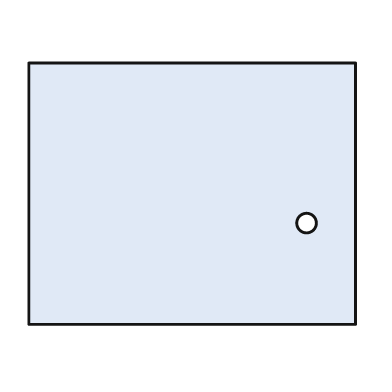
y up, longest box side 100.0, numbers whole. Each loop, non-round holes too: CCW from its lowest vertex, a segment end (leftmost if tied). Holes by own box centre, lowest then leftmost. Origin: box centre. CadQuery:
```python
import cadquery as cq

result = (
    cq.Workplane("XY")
    .moveTo(-50.0, -40.0)
    .lineTo(50.0, -40.0)
    .lineTo(50.0, 40.0)
    .lineTo(-50.0, 40.0)
    .close()
    .moveTo(35.0, -9.0)
    .circle(3.0)
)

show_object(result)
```